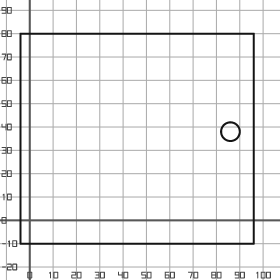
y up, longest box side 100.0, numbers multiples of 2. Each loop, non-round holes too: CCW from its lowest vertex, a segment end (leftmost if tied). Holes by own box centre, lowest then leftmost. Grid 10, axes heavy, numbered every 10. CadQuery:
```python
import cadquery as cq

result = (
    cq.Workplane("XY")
    .moveTo(-4.0, -10.0)
    .lineTo(96.0, -10.0)
    .lineTo(96.0, 80.0)
    .lineTo(-4.0, 80.0)
    .close()
    .moveTo(86.0, 38.0)
    .circle(4.0)
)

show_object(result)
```